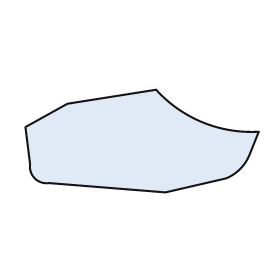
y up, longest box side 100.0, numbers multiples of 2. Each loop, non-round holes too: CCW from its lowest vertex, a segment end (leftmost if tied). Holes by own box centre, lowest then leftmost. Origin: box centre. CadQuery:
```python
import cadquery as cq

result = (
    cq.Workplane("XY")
    .moveTo(10.0, -22.0)
    .lineTo(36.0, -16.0)
    .threePointArc((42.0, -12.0), (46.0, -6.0))
    .lineTo(50.0, 4.0)
    .threePointArc((26.0, 8.0), (6.0, 22.0))
    .lineTo(-32.0, 16.0)
    .lineTo(-50.0, 6.0)
    .lineTo(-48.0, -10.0)
    .threePointArc((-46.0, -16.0), (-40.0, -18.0))
    .close()
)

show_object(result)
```